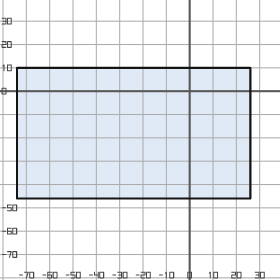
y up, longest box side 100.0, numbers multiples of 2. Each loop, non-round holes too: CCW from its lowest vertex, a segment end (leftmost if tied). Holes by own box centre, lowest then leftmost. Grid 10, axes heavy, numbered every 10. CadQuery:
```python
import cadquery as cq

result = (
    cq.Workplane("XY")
    .moveTo(-74.0, -46.0)
    .lineTo(26.0, -46.0)
    .lineTo(26.0, 10.0)
    .lineTo(-74.0, 10.0)
    .close()
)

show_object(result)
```